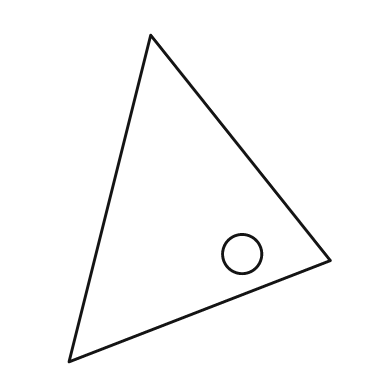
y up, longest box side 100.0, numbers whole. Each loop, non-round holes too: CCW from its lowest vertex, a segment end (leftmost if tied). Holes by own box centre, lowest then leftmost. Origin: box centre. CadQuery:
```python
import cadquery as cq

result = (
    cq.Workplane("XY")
    .moveTo(-40.0, -50.0)
    .lineTo(40.0, -19.0)
    .lineTo(-15.0, 50.0)
    .close()
    .moveTo(13.0, -17.0)
    .circle(6.0)
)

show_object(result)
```